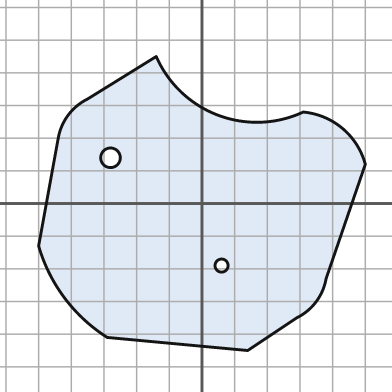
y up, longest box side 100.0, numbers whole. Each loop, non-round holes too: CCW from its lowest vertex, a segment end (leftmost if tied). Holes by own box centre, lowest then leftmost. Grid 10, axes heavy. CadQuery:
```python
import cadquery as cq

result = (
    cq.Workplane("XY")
    .moveTo(14.0, -45.0)
    .lineTo(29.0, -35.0)
    .threePointArc((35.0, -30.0), (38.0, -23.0))
    .lineTo(50.0, 12.0)
    .threePointArc((43.0, 23.0), (31.0, 28.0))
    .threePointArc((5.0, 27.0), (-14.0, 45.0))
    .lineTo(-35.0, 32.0)
    .threePointArc((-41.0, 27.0), (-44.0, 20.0))
    .lineTo(-50.0, -13.0)
    .threePointArc((-42.0, -29.0), (-29.0, -41.0))
    .close()
    .moveTo(6.0, -19.0)
    .circle(2.0)
    .moveTo(-28.0, 14.0)
    .circle(3.0)
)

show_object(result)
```